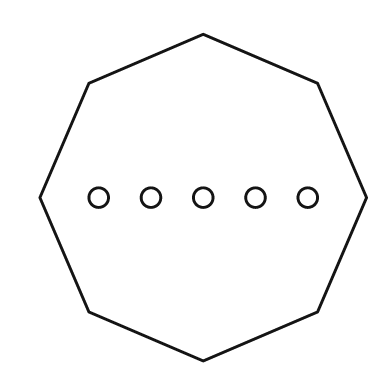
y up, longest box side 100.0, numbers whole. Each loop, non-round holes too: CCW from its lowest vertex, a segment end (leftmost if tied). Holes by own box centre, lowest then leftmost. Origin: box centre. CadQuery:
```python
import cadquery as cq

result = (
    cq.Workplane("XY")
    .moveTo(0.0, -50.0)
    .lineTo(35.0, -35.0)
    .lineTo(50.0, 0.0)
    .lineTo(35.0, 35.0)
    .lineTo(0.0, 50.0)
    .lineTo(-35.0, 35.0)
    .lineTo(-50.0, 0.0)
    .lineTo(-35.0, -35.0)
    .close()
    .moveTo(-32.0, 0.0)
    .circle(3.0)
    .moveTo(-16.0, 0.0)
    .circle(3.0)
    .moveTo(0.0, 0.0)
    .circle(3.0)
    .moveTo(16.0, 0.0)
    .circle(3.0)
    .moveTo(32.0, 0.0)
    .circle(3.0)
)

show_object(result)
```